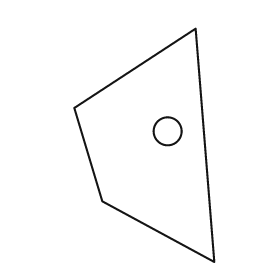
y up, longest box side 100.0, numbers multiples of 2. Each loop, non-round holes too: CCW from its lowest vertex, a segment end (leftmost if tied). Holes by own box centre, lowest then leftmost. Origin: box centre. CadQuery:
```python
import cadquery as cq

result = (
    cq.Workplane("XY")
    .moveTo(30.0, -50.0)
    .lineTo(22.0, 50.0)
    .lineTo(-30.0, 16.0)
    .lineTo(-18.0, -24.0)
    .close()
    .moveTo(10.0, 6.0)
    .circle(6.0)
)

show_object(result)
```